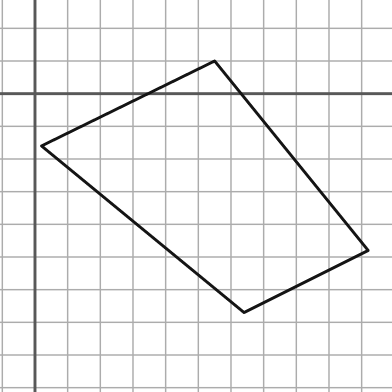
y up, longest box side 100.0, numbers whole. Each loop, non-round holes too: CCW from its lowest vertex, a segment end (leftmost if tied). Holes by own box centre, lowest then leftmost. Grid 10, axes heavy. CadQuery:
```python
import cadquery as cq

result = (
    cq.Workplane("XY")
    .moveTo(64.0, -67.0)
    .lineTo(102.0, -48.0)
    .lineTo(55.0, 10.0)
    .lineTo(2.0, -16.0)
    .close()
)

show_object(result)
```